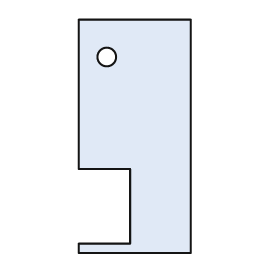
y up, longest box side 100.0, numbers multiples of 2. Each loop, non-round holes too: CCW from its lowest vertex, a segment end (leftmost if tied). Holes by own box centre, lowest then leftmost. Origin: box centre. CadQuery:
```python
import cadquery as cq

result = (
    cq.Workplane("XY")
    .moveTo(-24.0, -50.0)
    .lineTo(24.0, -50.0)
    .lineTo(24.0, 50.0)
    .lineTo(-24.0, 50.0)
    .lineTo(-24.0, -14.0)
    .lineTo(-2.0, -14.0)
    .lineTo(-2.0, -46.0)
    .lineTo(-24.0, -46.0)
    .close()
    .moveTo(-12.0, 34.0)
    .circle(4.0)
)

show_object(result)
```